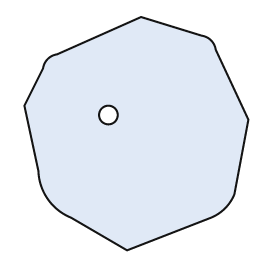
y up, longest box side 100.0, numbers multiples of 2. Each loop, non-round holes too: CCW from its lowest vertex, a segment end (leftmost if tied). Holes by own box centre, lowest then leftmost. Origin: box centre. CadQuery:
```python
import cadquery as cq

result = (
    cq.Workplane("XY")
    .moveTo(-4.0, -50.0)
    .lineTo(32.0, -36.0)
    .threePointArc((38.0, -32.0), (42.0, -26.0))
    .lineTo(48.0, 6.0)
    .lineTo(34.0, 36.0)
    .threePointArc((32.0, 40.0), (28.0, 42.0))
    .lineTo(2.0, 50.0)
    .lineTo(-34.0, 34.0)
    .threePointArc((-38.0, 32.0), (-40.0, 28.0))
    .lineTo(-48.0, 12.0)
    .lineTo(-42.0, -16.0)
    .threePointArc((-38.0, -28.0), (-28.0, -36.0))
    .close()
    .moveTo(-12.0, 8.0)
    .circle(4.0)
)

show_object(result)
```